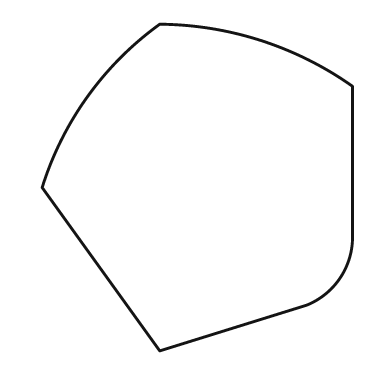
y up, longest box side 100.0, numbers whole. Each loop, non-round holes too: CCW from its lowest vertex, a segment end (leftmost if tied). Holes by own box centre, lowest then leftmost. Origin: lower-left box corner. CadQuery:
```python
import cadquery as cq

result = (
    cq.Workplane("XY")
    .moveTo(36.0, 0.0)
    .lineTo(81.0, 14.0)
    .threePointArc((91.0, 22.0), (95.0, 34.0))
    .lineTo(95.0, 81.0)
    .threePointArc((67.0, 95.0), (36.0, 100.0))
    .threePointArc((14.0, 78.0), (0.0, 50.0))
    .close()
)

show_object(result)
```